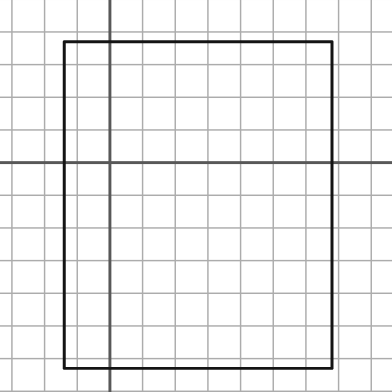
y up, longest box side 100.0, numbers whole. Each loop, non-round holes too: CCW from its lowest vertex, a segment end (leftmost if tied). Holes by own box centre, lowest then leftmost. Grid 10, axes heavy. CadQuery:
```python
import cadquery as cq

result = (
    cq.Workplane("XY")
    .moveTo(-14.0, -63.0)
    .lineTo(68.0, -63.0)
    .lineTo(68.0, 37.0)
    .lineTo(-14.0, 37.0)
    .close()
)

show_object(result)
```